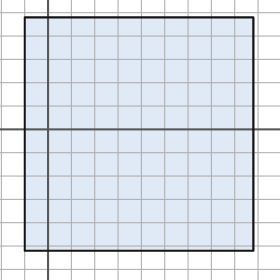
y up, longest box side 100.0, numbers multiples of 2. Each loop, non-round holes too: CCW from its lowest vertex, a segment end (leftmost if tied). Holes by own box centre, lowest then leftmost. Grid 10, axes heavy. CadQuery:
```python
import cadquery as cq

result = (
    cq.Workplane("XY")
    .moveTo(-10.0, -52.0)
    .lineTo(88.0, -52.0)
    .lineTo(88.0, 48.0)
    .lineTo(-10.0, 48.0)
    .close()
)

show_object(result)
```